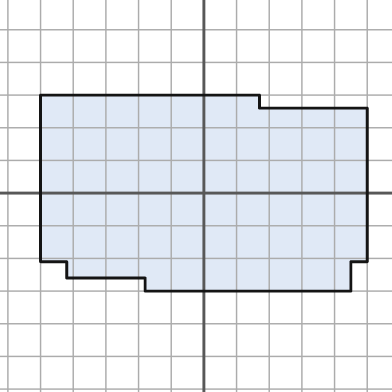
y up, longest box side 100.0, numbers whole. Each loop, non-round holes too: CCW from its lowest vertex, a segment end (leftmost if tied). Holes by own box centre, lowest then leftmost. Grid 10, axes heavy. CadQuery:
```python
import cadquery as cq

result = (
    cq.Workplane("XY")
    .moveTo(-18.0, -30.0)
    .lineTo(45.0, -30.0)
    .lineTo(45.0, -21.0)
    .lineTo(50.0, -21.0)
    .lineTo(50.0, 26.0)
    .lineTo(17.0, 26.0)
    .lineTo(17.0, 30.0)
    .lineTo(-50.0, 30.0)
    .lineTo(-50.0, -21.0)
    .lineTo(-42.0, -21.0)
    .lineTo(-42.0, -26.0)
    .lineTo(-18.0, -26.0)
    .close()
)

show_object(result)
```